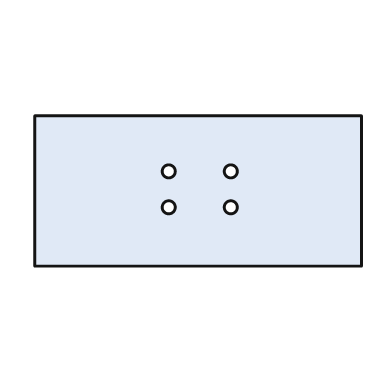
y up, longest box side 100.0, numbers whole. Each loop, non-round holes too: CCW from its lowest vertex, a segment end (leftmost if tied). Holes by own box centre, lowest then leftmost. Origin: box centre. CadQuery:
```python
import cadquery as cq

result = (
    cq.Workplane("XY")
    .moveTo(-50.0, -23.0)
    .lineTo(50.0, -23.0)
    .lineTo(50.0, 23.0)
    .lineTo(-50.0, 23.0)
    .close()
    .moveTo(-9.0, -5.0)
    .circle(2.0)
    .moveTo(10.0, -5.0)
    .circle(2.0)
    .moveTo(-9.0, 6.0)
    .circle(2.0)
    .moveTo(10.0, 6.0)
    .circle(2.0)
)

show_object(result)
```